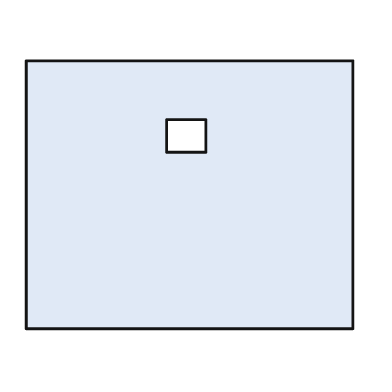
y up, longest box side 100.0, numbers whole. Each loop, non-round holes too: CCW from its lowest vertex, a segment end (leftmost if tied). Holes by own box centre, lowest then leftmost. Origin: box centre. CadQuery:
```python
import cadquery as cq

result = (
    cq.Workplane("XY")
    .moveTo(-50.0, -41.0)
    .lineTo(50.0, -41.0)
    .lineTo(50.0, 41.0)
    .lineTo(-50.0, 41.0)
    .close()
    .moveTo(-7.0, 13.0)
    .lineTo(5.0, 13.0)
    .lineTo(5.0, 23.0)
    .lineTo(-7.0, 23.0)
    .close()
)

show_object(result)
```